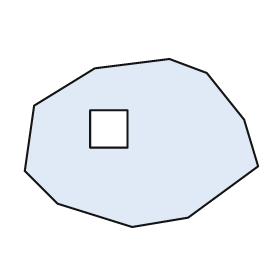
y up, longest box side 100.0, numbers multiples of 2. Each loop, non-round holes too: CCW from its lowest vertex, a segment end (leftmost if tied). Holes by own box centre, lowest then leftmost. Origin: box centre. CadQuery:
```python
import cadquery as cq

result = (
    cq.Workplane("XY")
    .moveTo(-4.0, -36.0)
    .lineTo(20.0, -32.0)
    .lineTo(50.0, -10.0)
    .lineTo(44.0, 10.0)
    .lineTo(28.0, 30.0)
    .lineTo(12.0, 36.0)
    .lineTo(-20.0, 32.0)
    .lineTo(-46.0, 16.0)
    .lineTo(-50.0, -12.0)
    .lineTo(-36.0, -26.0)
    .close()
    .moveTo(-22.0, -2.0)
    .lineTo(-6.0, -2.0)
    .lineTo(-6.0, 14.0)
    .lineTo(-22.0, 14.0)
    .close()
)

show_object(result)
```